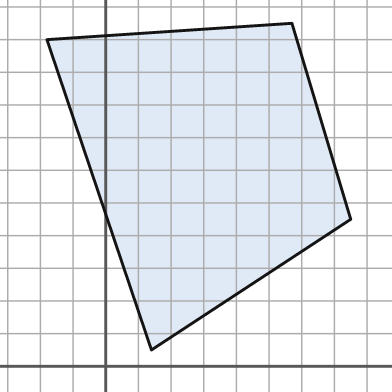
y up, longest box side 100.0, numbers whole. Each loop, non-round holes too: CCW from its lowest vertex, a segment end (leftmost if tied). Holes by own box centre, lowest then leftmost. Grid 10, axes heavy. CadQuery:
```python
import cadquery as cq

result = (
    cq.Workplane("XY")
    .moveTo(14.0, 5.0)
    .lineTo(75.0, 45.0)
    .lineTo(57.0, 105.0)
    .lineTo(-18.0, 100.0)
    .close()
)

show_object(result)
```